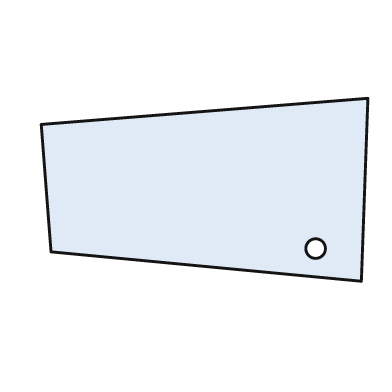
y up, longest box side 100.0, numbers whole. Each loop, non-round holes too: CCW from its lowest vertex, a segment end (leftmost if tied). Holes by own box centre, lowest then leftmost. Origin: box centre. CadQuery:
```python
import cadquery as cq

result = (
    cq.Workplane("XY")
    .moveTo(48.0, -28.0)
    .lineTo(50.0, 28.0)
    .lineTo(-50.0, 20.0)
    .lineTo(-47.0, -19.0)
    .close()
    .moveTo(34.0, -18.0)
    .circle(3.0)
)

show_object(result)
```